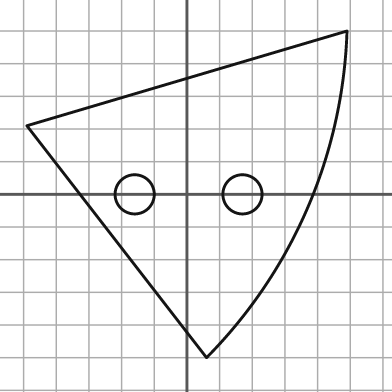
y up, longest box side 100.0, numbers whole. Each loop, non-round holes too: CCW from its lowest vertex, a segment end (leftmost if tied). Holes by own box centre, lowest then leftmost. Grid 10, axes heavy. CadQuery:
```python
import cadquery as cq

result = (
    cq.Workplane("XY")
    .moveTo(6.0, -50.0)
    .threePointArc((37.0, -4.0), (49.0, 50.0))
    .lineTo(-49.0, 21.0)
    .close()
    .moveTo(-16.0, 0.0)
    .circle(6.0)
    .moveTo(17.0, 0.0)
    .circle(6.0)
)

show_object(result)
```